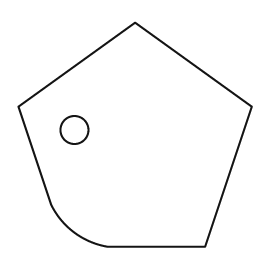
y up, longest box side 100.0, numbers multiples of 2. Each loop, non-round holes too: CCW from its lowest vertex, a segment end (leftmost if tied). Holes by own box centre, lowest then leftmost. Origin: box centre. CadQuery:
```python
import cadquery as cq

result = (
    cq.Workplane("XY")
    .moveTo(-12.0, -48.0)
    .lineTo(30.0, -48.0)
    .lineTo(50.0, 12.0)
    .lineTo(0.0, 48.0)
    .lineTo(-50.0, 12.0)
    .lineTo(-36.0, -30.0)
    .threePointArc((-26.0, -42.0), (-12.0, -48.0))
    .close()
    .moveTo(-26.0, 2.0)
    .circle(6.0)
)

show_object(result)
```